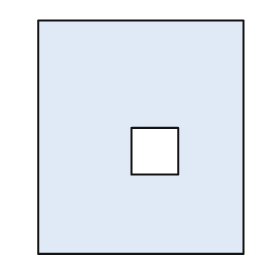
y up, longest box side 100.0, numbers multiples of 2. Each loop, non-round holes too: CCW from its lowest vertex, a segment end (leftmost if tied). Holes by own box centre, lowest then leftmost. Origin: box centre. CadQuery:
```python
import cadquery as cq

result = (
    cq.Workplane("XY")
    .moveTo(-44.0, -50.0)
    .lineTo(44.0, -50.0)
    .lineTo(44.0, 50.0)
    .lineTo(-44.0, 50.0)
    .close()
    .moveTo(-4.0, -16.0)
    .lineTo(16.0, -16.0)
    .lineTo(16.0, 4.0)
    .lineTo(-4.0, 4.0)
    .close()
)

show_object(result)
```